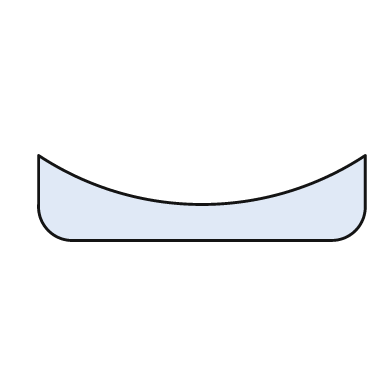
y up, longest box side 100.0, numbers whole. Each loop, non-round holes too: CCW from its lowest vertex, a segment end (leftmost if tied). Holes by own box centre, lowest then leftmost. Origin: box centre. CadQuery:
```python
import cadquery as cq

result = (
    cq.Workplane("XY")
    .moveTo(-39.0, -13.0)
    .lineTo(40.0, -13.0)
    .threePointArc((47.0, -10.0), (50.0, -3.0))
    .lineTo(50.0, 13.0)
    .threePointArc((0.0, -2.0), (-50.0, 13.0))
    .lineTo(-50.0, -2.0)
    .threePointArc((-47.0, -10.0), (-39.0, -13.0))
    .close()
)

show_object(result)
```